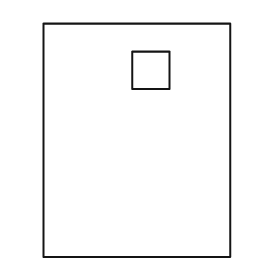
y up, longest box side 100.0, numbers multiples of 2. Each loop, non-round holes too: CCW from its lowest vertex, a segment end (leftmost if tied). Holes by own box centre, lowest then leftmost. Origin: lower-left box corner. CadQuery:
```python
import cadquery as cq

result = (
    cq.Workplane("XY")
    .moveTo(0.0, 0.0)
    .lineTo(80.0, 0.0)
    .lineTo(80.0, 100.0)
    .lineTo(0.0, 100.0)
    .close()
    .moveTo(38.0, 72.0)
    .lineTo(54.0, 72.0)
    .lineTo(54.0, 88.0)
    .lineTo(38.0, 88.0)
    .close()
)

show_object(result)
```